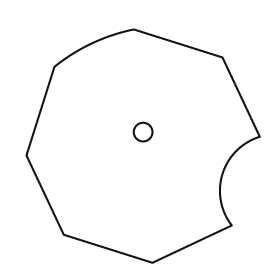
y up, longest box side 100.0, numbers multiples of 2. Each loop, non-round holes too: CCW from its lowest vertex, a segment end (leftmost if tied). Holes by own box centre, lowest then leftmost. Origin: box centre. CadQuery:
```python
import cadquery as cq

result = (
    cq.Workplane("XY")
    .moveTo(4.0, -50.0)
    .lineTo(38.0, -34.0)
    .threePointArc((34.0, -12.0), (50.0, 4.0))
    .lineTo(34.0, 38.0)
    .lineTo(-4.0, 50.0)
    .threePointArc((-22.0, 44.0), (-38.0, 34.0))
    .lineTo(-50.0, -4.0)
    .lineTo(-34.0, -38.0)
    .close()
    .moveTo(0.0, 6.0)
    .circle(4.0)
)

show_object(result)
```